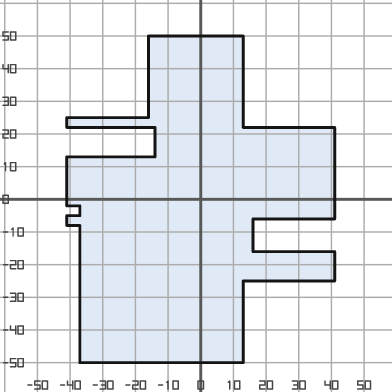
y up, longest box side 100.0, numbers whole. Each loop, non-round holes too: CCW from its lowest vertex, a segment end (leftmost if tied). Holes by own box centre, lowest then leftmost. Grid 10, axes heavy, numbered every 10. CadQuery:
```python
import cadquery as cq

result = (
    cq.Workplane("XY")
    .moveTo(-37.0, -50.0)
    .lineTo(13.0, -50.0)
    .lineTo(13.0, -25.0)
    .lineTo(41.0, -25.0)
    .lineTo(41.0, -16.0)
    .lineTo(16.0, -16.0)
    .lineTo(16.0, -6.0)
    .lineTo(41.0, -6.0)
    .lineTo(41.0, 22.0)
    .lineTo(13.0, 22.0)
    .lineTo(13.0, 50.0)
    .lineTo(-16.0, 50.0)
    .lineTo(-16.0, 25.0)
    .lineTo(-41.0, 25.0)
    .lineTo(-41.0, 22.0)
    .lineTo(-14.0, 22.0)
    .lineTo(-14.0, 13.0)
    .lineTo(-41.0, 13.0)
    .lineTo(-41.0, -2.0)
    .lineTo(-37.0, -2.0)
    .lineTo(-37.0, -5.0)
    .lineTo(-41.0, -5.0)
    .lineTo(-41.0, -8.0)
    .lineTo(-37.0, -8.0)
    .close()
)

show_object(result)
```